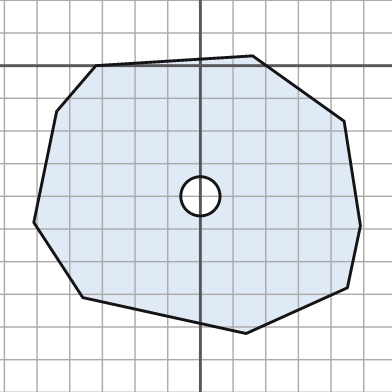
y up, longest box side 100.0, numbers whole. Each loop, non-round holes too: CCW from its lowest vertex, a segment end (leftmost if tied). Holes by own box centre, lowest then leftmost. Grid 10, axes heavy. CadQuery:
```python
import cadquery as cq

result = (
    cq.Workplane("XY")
    .moveTo(14.0, -82.0)
    .lineTo(45.0, -68.0)
    .lineTo(49.0, -49.0)
    .lineTo(44.0, -17.0)
    .lineTo(16.0, 3.0)
    .lineTo(-32.0, 0.0)
    .lineTo(-44.0, -14.0)
    .lineTo(-51.0, -48.0)
    .lineTo(-36.0, -71.0)
    .close()
    .moveTo(0.0, -40.0)
    .circle(6.0)
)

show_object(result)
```